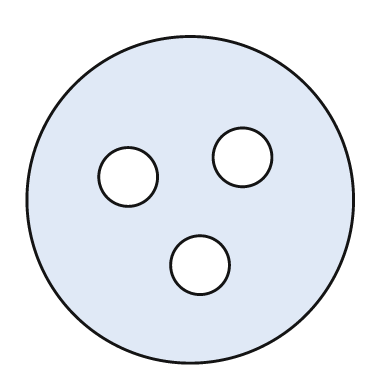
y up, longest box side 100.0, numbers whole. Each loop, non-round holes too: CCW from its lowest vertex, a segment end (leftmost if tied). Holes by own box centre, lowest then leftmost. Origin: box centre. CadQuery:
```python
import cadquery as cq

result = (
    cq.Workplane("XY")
    .moveTo(0.0, 0.0)
    .circle(50.0)
    .moveTo(3.0, -20.0)
    .circle(9.0)
    .moveTo(-19.0, 7.0)
    .circle(9.0)
    .moveTo(16.0, 13.0)
    .circle(9.0)
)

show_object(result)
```